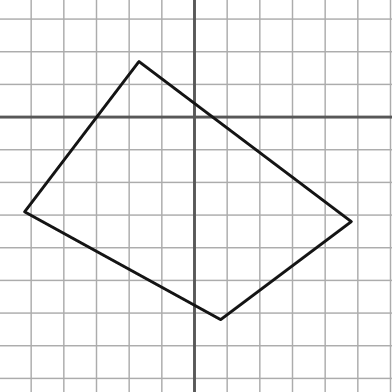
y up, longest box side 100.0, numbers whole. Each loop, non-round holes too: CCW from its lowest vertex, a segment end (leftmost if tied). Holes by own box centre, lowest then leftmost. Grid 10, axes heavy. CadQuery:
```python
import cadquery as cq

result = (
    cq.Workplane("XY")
    .moveTo(8.0, -62.0)
    .lineTo(48.0, -32.0)
    .lineTo(-17.0, 17.0)
    .lineTo(-52.0, -29.0)
    .close()
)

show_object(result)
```